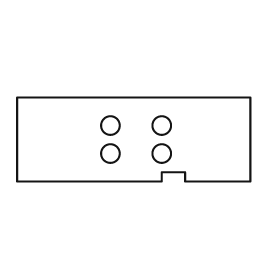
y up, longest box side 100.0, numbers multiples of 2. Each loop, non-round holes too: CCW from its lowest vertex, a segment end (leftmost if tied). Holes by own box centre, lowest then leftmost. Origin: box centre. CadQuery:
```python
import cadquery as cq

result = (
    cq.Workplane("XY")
    .moveTo(-50.0, -18.0)
    .lineTo(12.0, -18.0)
    .lineTo(12.0, -14.0)
    .lineTo(22.0, -14.0)
    .lineTo(22.0, -18.0)
    .lineTo(50.0, -18.0)
    .lineTo(50.0, 18.0)
    .lineTo(-50.0, 18.0)
    .close()
    .moveTo(-10.0, -6.0)
    .circle(4.0)
    .moveTo(12.0, -6.0)
    .circle(4.0)
    .moveTo(-10.0, 6.0)
    .circle(4.0)
    .moveTo(12.0, 6.0)
    .circle(4.0)
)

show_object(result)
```